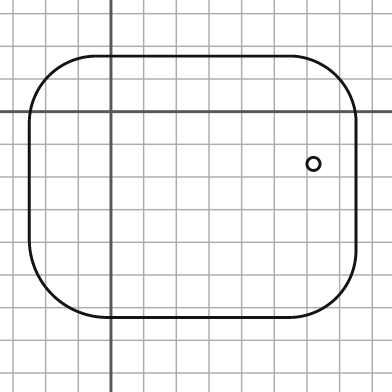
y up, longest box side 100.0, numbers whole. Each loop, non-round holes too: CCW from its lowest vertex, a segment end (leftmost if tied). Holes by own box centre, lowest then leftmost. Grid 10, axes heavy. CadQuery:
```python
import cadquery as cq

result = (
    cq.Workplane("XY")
    .moveTo(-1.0, -63.0)
    .lineTo(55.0, -63.0)
    .threePointArc((69.0, -57.0), (75.0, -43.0))
    .lineTo(75.0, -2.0)
    .threePointArc((69.0, 11.0), (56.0, 17.0))
    .lineTo(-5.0, 17.0)
    .threePointArc((-19.0, 11.0), (-25.0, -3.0))
    .lineTo(-25.0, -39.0)
    .threePointArc((-18.0, -56.0), (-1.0, -63.0))
    .close()
    .moveTo(62.0, -16.0)
    .circle(2.0)
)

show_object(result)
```